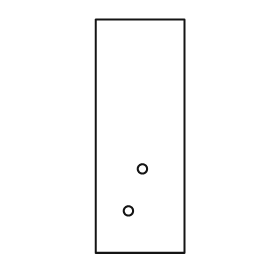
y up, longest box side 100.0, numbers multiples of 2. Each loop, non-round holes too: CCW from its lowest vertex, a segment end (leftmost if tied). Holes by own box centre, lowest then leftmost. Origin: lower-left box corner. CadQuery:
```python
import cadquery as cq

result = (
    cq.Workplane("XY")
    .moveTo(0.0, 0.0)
    .lineTo(38.0, 0.0)
    .lineTo(38.0, 100.0)
    .lineTo(0.0, 100.0)
    .close()
    .moveTo(14.0, 18.0)
    .circle(2.0)
    .moveTo(20.0, 36.0)
    .circle(2.0)
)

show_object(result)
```